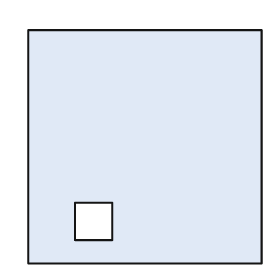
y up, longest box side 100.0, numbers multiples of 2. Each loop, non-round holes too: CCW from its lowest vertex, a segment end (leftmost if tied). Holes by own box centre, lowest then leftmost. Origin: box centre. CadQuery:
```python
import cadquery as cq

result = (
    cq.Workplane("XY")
    .moveTo(-50.0, -50.0)
    .lineTo(50.0, -50.0)
    .lineTo(50.0, 50.0)
    .lineTo(-50.0, 50.0)
    .close()
    .moveTo(-30.0, -40.0)
    .lineTo(-14.0, -40.0)
    .lineTo(-14.0, -24.0)
    .lineTo(-30.0, -24.0)
    .close()
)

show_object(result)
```